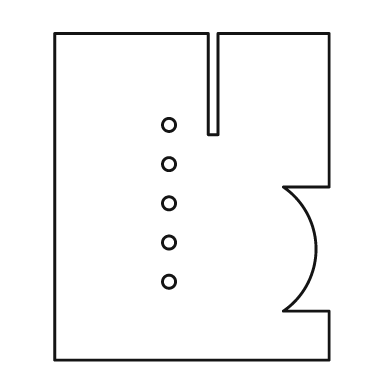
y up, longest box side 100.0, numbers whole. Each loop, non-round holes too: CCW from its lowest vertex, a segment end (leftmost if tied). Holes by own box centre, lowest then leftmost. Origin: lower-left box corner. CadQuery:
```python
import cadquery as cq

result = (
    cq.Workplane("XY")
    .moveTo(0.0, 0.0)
    .lineTo(84.0, 0.0)
    .lineTo(84.0, 15.0)
    .lineTo(70.0, 15.0)
    .threePointArc((80.0, 34.0), (70.0, 53.0))
    .lineTo(84.0, 53.0)
    .lineTo(84.0, 100.0)
    .lineTo(50.0, 100.0)
    .lineTo(50.0, 69.0)
    .lineTo(47.0, 69.0)
    .lineTo(47.0, 100.0)
    .lineTo(0.0, 100.0)
    .close()
    .moveTo(35.0, 24.0)
    .circle(2.0)
    .moveTo(35.0, 36.0)
    .circle(2.0)
    .moveTo(35.0, 48.0)
    .circle(2.0)
    .moveTo(35.0, 60.0)
    .circle(2.0)
    .moveTo(35.0, 72.0)
    .circle(2.0)
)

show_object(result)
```